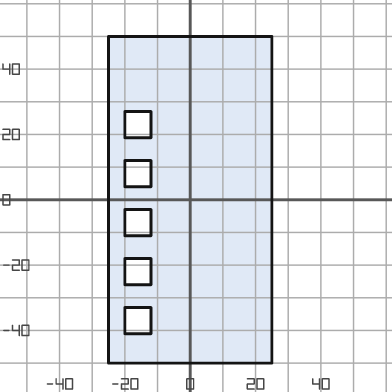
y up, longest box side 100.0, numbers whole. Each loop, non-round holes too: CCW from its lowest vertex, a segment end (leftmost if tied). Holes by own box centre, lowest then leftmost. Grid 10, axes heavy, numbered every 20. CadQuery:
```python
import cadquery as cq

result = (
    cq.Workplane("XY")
    .moveTo(-25.0, -50.0)
    .lineTo(25.0, -50.0)
    .lineTo(25.0, 50.0)
    .lineTo(-25.0, 50.0)
    .close()
    .moveTo(-20.0, -41.0)
    .lineTo(-12.0, -41.0)
    .lineTo(-12.0, -33.0)
    .lineTo(-20.0, -33.0)
    .close()
    .moveTo(-20.0, -26.0)
    .lineTo(-12.0, -26.0)
    .lineTo(-12.0, -18.0)
    .lineTo(-20.0, -18.0)
    .close()
    .moveTo(-20.0, -11.0)
    .lineTo(-12.0, -11.0)
    .lineTo(-12.0, -3.0)
    .lineTo(-20.0, -3.0)
    .close()
    .moveTo(-20.0, 4.0)
    .lineTo(-12.0, 4.0)
    .lineTo(-12.0, 12.0)
    .lineTo(-20.0, 12.0)
    .close()
    .moveTo(-20.0, 19.0)
    .lineTo(-12.0, 19.0)
    .lineTo(-12.0, 27.0)
    .lineTo(-20.0, 27.0)
    .close()
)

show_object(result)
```